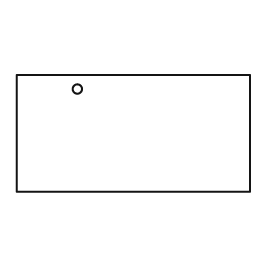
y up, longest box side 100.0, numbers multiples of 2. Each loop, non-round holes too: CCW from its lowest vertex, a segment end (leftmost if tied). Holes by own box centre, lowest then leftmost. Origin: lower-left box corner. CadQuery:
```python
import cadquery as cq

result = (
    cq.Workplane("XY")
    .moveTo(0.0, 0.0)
    .lineTo(100.0, 0.0)
    .lineTo(100.0, 50.0)
    .lineTo(0.0, 50.0)
    .close()
    .moveTo(26.0, 44.0)
    .circle(2.0)
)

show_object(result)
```